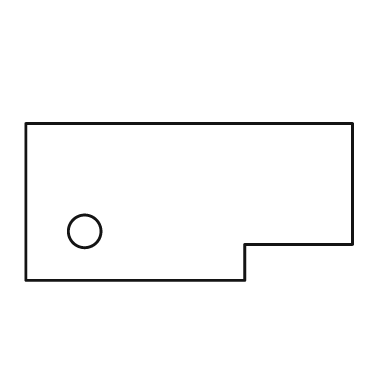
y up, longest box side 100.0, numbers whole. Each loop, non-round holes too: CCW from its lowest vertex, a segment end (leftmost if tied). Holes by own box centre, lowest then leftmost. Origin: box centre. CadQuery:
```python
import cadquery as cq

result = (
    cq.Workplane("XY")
    .moveTo(-50.0, -24.0)
    .lineTo(17.0, -24.0)
    .lineTo(17.0, -13.0)
    .lineTo(50.0, -13.0)
    .lineTo(50.0, 24.0)
    .lineTo(-50.0, 24.0)
    .close()
    .moveTo(-32.0, -9.0)
    .circle(5.0)
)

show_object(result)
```